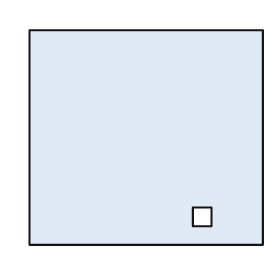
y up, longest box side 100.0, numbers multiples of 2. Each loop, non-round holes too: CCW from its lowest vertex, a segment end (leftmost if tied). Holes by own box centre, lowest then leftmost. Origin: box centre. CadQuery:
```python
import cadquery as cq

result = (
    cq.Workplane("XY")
    .moveTo(-50.0, -46.0)
    .lineTo(50.0, -46.0)
    .lineTo(50.0, 46.0)
    .lineTo(-50.0, 46.0)
    .close()
    .moveTo(20.0, -38.0)
    .lineTo(28.0, -38.0)
    .lineTo(28.0, -30.0)
    .lineTo(20.0, -30.0)
    .close()
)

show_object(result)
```